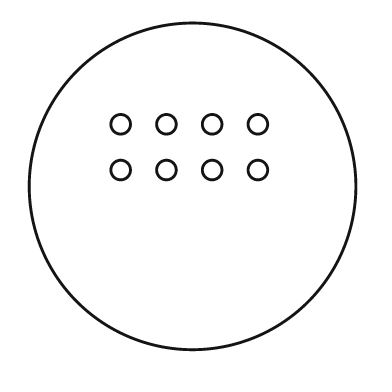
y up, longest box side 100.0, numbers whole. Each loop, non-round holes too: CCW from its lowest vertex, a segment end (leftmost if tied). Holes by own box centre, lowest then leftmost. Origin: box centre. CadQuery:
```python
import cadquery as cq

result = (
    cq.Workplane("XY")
    .moveTo(0.0, 0.0)
    .circle(50.0)
    .moveTo(-22.0, 5.0)
    .circle(3.0)
    .moveTo(-8.0, 5.0)
    .circle(3.0)
    .moveTo(6.0, 5.0)
    .circle(3.0)
    .moveTo(20.0, 5.0)
    .circle(3.0)
    .moveTo(-22.0, 19.0)
    .circle(3.0)
    .moveTo(-8.0, 19.0)
    .circle(3.0)
    .moveTo(6.0, 19.0)
    .circle(3.0)
    .moveTo(20.0, 19.0)
    .circle(3.0)
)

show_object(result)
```